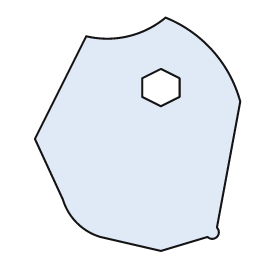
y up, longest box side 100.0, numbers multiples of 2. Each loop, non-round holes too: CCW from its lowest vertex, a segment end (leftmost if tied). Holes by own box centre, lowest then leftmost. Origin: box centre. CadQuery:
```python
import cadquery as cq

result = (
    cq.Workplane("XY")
    .moveTo(10.0, -50.0)
    .lineTo(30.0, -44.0)
    .threePointArc((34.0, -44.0), (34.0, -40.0))
    .lineTo(44.0, 14.0)
    .threePointArc((32.0, 36.0), (12.0, 50.0))
    .threePointArc((-4.0, 42.0), (-22.0, 42.0))
    .lineTo(-44.0, -2.0)
    .lineTo(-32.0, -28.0)
    .threePointArc((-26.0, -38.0), (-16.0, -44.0))
    .close()
    .moveTo(10.0, 12.0)
    .lineTo(18.0, 16.0)
    .lineTo(18.0, 24.0)
    .lineTo(10.0, 28.0)
    .lineTo(2.0, 24.0)
    .lineTo(2.0, 16.0)
    .close()
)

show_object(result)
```